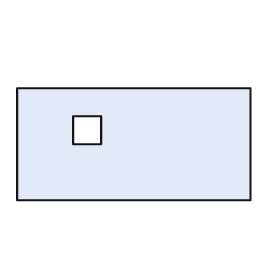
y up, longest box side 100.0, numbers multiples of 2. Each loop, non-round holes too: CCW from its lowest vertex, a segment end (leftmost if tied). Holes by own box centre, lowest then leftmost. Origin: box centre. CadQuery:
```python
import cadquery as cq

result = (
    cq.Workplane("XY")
    .moveTo(-50.0, -24.0)
    .lineTo(50.0, -24.0)
    .lineTo(50.0, 24.0)
    .lineTo(-50.0, 24.0)
    .close()
    .moveTo(-26.0, 0.0)
    .lineTo(-14.0, 0.0)
    .lineTo(-14.0, 12.0)
    .lineTo(-26.0, 12.0)
    .close()
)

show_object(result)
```